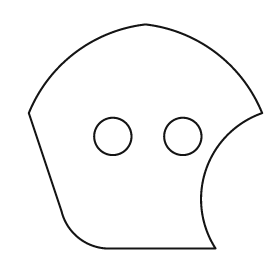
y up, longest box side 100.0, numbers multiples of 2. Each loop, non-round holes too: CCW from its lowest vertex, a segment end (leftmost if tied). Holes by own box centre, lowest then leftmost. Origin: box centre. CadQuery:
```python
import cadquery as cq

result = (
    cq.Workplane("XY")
    .moveTo(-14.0, -48.0)
    .lineTo(30.0, -48.0)
    .threePointArc((26.0, -14.0), (50.0, 10.0))
    .threePointArc((30.0, 36.0), (0.0, 48.0))
    .threePointArc((-30.0, 36.0), (-50.0, 10.0))
    .lineTo(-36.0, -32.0)
    .threePointArc((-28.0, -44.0), (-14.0, -48.0))
    .close()
    .moveTo(-14.0, 0.0)
    .circle(8.0)
    .moveTo(16.0, 0.0)
    .circle(8.0)
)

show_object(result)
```